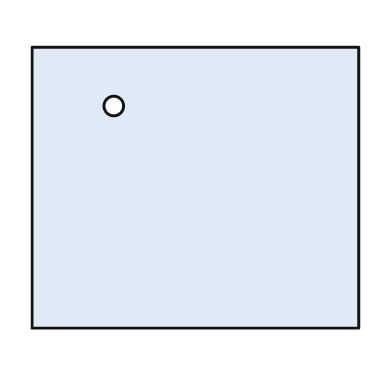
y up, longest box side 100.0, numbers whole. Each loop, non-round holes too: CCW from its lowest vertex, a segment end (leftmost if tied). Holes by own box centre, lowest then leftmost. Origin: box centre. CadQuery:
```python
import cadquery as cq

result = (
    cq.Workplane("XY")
    .moveTo(-50.0, -43.0)
    .lineTo(50.0, -43.0)
    .lineTo(50.0, 43.0)
    .lineTo(-50.0, 43.0)
    .close()
    .moveTo(-25.0, 25.0)
    .circle(3.0)
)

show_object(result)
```